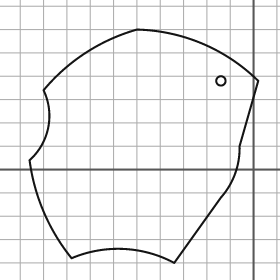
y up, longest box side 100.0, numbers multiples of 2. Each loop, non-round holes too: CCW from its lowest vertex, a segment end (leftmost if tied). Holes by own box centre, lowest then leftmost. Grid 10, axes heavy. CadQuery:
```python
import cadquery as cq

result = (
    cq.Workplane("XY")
    .moveTo(-34.0, -40.0)
    .lineTo(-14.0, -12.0)
    .threePointArc((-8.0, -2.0), (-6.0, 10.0))
    .lineTo(2.0, 38.0)
    .threePointArc((-22.0, 54.0), (-50.0, 60.0))
    .threePointArc((-72.0, 50.0), (-90.0, 34.0))
    .threePointArc((-88.0, 18.0), (-96.0, 4.0))
    .threePointArc((-90.0, -18.0), (-78.0, -38.0))
    .threePointArc((-56.0, -34.0), (-34.0, -40.0))
    .close()
    .moveTo(-14.0, 38.0)
    .circle(2.0)
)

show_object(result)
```